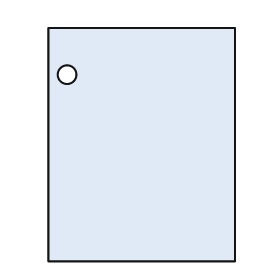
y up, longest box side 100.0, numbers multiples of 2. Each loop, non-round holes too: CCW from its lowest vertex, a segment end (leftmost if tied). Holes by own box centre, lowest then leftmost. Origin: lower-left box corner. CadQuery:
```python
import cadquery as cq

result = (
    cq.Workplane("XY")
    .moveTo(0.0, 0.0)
    .lineTo(80.0, 0.0)
    .lineTo(80.0, 100.0)
    .lineTo(0.0, 100.0)
    .close()
    .moveTo(8.0, 80.0)
    .circle(4.0)
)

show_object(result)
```